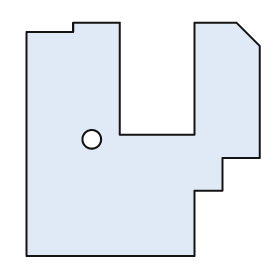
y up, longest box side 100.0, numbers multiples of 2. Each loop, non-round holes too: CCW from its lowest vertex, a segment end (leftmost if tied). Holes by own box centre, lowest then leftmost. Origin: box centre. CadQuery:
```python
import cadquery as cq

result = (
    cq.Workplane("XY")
    .moveTo(-50.0, -50.0)
    .lineTo(22.0, -50.0)
    .lineTo(22.0, -22.0)
    .lineTo(34.0, -22.0)
    .lineTo(34.0, -8.0)
    .lineTo(50.0, -8.0)
    .lineTo(50.0, 40.0)
    .lineTo(40.0, 50.0)
    .lineTo(22.0, 50.0)
    .lineTo(22.0, 2.0)
    .lineTo(-10.0, 2.0)
    .lineTo(-10.0, 50.0)
    .lineTo(-30.0, 50.0)
    .lineTo(-30.0, 46.0)
    .lineTo(-50.0, 46.0)
    .close()
    .moveTo(-22.0, 0.0)
    .circle(4.0)
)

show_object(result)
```